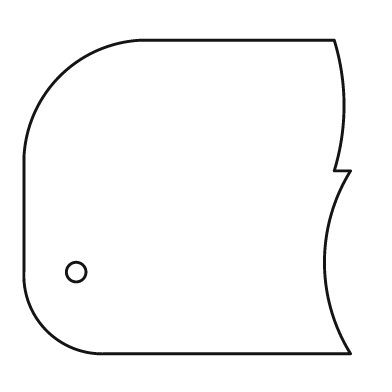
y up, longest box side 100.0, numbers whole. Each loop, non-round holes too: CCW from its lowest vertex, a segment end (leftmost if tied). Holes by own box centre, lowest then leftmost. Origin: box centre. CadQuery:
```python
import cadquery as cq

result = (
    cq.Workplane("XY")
    .moveTo(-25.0, -48.0)
    .lineTo(50.0, -48.0)
    .threePointArc((42.0, -20.0), (50.0, 8.0))
    .lineTo(45.0, 8.0)
    .threePointArc((48.0, 28.0), (45.0, 48.0))
    .lineTo(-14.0, 48.0)
    .threePointArc((-39.0, 37.0), (-50.0, 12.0))
    .lineTo(-50.0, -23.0)
    .threePointArc((-43.0, -41.0), (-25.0, -48.0))
    .close()
    .moveTo(-34.0, -23.0)
    .circle(3.0)
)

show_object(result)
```